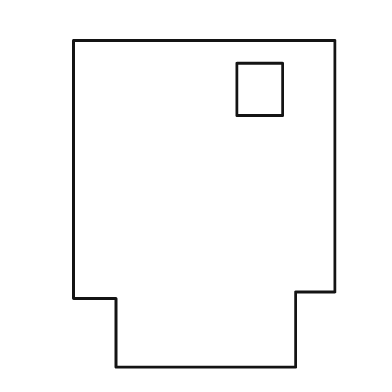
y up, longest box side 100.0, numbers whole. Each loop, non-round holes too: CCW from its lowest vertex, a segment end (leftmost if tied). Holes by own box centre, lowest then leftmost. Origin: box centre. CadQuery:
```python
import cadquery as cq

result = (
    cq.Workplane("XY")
    .moveTo(-27.0, -50.0)
    .lineTo(28.0, -50.0)
    .lineTo(28.0, -27.0)
    .lineTo(40.0, -27.0)
    .lineTo(40.0, 50.0)
    .lineTo(-40.0, 50.0)
    .lineTo(-40.0, -29.0)
    .lineTo(-27.0, -29.0)
    .close()
    .moveTo(10.0, 27.0)
    .lineTo(24.0, 27.0)
    .lineTo(24.0, 43.0)
    .lineTo(10.0, 43.0)
    .close()
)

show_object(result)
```